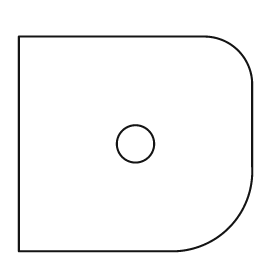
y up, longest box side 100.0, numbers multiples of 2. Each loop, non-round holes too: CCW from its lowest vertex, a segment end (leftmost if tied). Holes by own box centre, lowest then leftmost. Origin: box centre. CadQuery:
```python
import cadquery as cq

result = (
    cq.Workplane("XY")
    .moveTo(-50.0, -46.0)
    .lineTo(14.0, -46.0)
    .threePointArc((40.0, -36.0), (50.0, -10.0))
    .lineTo(50.0, 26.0)
    .threePointArc((44.0, 40.0), (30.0, 46.0))
    .lineTo(-50.0, 46.0)
    .close()
    .moveTo(0.0, 0.0)
    .circle(8.0)
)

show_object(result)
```